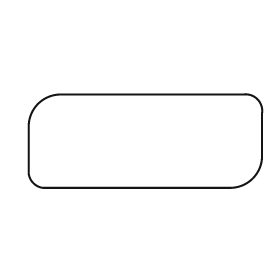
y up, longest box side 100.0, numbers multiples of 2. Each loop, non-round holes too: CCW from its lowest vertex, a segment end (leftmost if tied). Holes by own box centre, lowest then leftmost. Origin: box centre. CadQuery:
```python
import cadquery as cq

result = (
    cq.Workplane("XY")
    .moveTo(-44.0, -20.0)
    .lineTo(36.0, -20.0)
    .threePointArc((46.0, -16.0), (50.0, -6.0))
    .lineTo(50.0, 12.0)
    .threePointArc((48.0, 18.0), (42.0, 20.0))
    .lineTo(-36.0, 20.0)
    .threePointArc((-46.0, 16.0), (-50.0, 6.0))
    .lineTo(-50.0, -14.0)
    .threePointArc((-48.0, -18.0), (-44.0, -20.0))
    .close()
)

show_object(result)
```